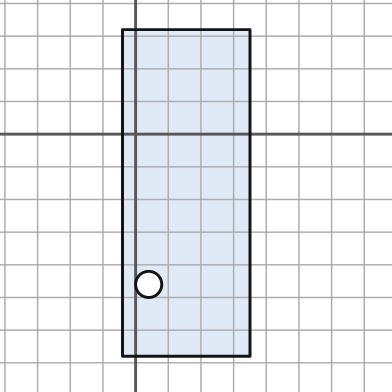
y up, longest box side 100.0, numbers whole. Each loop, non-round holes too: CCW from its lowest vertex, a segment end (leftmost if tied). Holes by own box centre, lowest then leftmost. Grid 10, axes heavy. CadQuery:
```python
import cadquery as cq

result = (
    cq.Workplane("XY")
    .moveTo(-4.0, -68.0)
    .lineTo(35.0, -68.0)
    .lineTo(35.0, 32.0)
    .lineTo(-4.0, 32.0)
    .close()
    .moveTo(4.0, -46.0)
    .circle(4.0)
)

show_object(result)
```